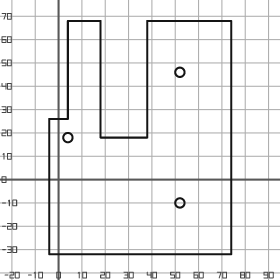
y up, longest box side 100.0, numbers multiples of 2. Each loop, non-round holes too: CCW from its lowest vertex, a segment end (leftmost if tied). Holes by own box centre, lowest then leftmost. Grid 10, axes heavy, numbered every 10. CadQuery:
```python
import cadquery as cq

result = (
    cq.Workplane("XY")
    .moveTo(-4.0, -32.0)
    .lineTo(74.0, -32.0)
    .lineTo(74.0, 68.0)
    .lineTo(38.0, 68.0)
    .lineTo(38.0, 18.0)
    .lineTo(18.0, 18.0)
    .lineTo(18.0, 68.0)
    .lineTo(4.0, 68.0)
    .lineTo(4.0, 26.0)
    .lineTo(-4.0, 26.0)
    .close()
    .moveTo(52.0, -10.0)
    .circle(2.0)
    .moveTo(4.0, 18.0)
    .circle(2.0)
    .moveTo(52.0, 46.0)
    .circle(2.0)
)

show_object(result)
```